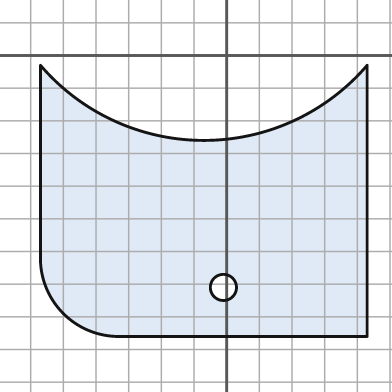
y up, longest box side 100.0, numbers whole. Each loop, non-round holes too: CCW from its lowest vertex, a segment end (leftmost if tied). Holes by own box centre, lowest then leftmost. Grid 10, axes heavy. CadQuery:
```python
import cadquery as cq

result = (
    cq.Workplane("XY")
    .moveTo(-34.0, -86.0)
    .lineTo(43.0, -86.0)
    .lineTo(43.0, -3.0)
    .threePointArc((-7.0, -26.0), (-57.0, -3.0))
    .lineTo(-57.0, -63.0)
    .threePointArc((-50.0, -79.0), (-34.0, -86.0))
    .close()
    .moveTo(-1.0, -71.0)
    .circle(4.0)
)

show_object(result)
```